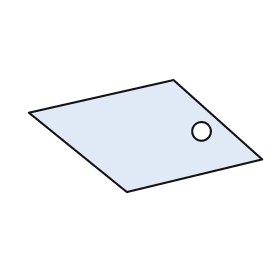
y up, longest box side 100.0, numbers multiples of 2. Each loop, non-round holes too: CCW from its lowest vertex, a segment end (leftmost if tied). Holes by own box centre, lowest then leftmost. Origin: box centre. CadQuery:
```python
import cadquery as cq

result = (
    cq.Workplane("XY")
    .moveTo(-8.0, -24.0)
    .lineTo(50.0, -10.0)
    .lineTo(12.0, 24.0)
    .lineTo(-50.0, 10.0)
    .close()
    .moveTo(24.0, 2.0)
    .circle(4.0)
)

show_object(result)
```